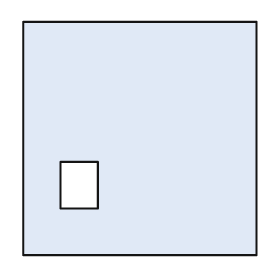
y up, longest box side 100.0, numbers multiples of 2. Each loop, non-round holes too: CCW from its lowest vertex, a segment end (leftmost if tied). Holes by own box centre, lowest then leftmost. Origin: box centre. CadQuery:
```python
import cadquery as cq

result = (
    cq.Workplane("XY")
    .moveTo(-50.0, -50.0)
    .lineTo(50.0, -50.0)
    .lineTo(50.0, 50.0)
    .lineTo(-50.0, 50.0)
    .close()
    .moveTo(-34.0, -30.0)
    .lineTo(-18.0, -30.0)
    .lineTo(-18.0, -10.0)
    .lineTo(-34.0, -10.0)
    .close()
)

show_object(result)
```